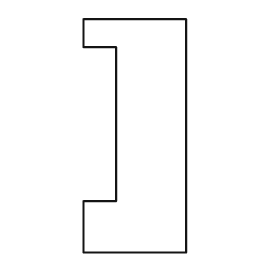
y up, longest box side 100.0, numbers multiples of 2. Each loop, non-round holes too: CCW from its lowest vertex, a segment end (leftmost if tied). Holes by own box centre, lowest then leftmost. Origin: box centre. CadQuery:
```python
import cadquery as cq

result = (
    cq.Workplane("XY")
    .moveTo(-22.0, -50.0)
    .lineTo(22.0, -50.0)
    .lineTo(22.0, 50.0)
    .lineTo(-22.0, 50.0)
    .lineTo(-22.0, 38.0)
    .lineTo(-8.0, 38.0)
    .lineTo(-8.0, -28.0)
    .lineTo(-22.0, -28.0)
    .close()
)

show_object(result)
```